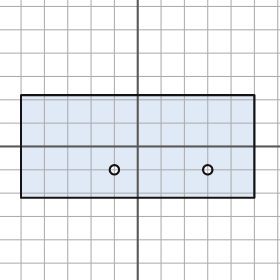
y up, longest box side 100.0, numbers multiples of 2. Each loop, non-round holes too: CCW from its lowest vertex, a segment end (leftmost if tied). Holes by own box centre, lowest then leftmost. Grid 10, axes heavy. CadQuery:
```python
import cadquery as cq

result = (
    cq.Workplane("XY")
    .moveTo(-50.0, -22.0)
    .lineTo(50.0, -22.0)
    .lineTo(50.0, 22.0)
    .lineTo(-50.0, 22.0)
    .close()
    .moveTo(-10.0, -10.0)
    .circle(2.0)
    .moveTo(30.0, -10.0)
    .circle(2.0)
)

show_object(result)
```